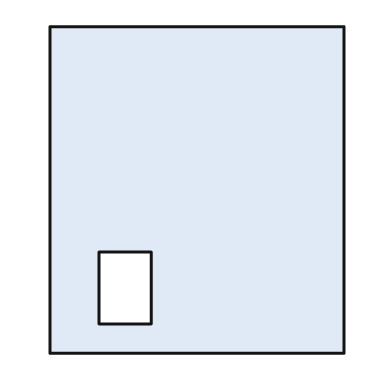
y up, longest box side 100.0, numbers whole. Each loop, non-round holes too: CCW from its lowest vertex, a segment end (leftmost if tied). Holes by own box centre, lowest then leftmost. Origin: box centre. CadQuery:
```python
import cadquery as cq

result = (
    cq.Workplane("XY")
    .moveTo(-45.0, -50.0)
    .lineTo(45.0, -50.0)
    .lineTo(45.0, 50.0)
    .lineTo(-45.0, 50.0)
    .close()
    .moveTo(-30.0, -41.0)
    .lineTo(-14.0, -41.0)
    .lineTo(-14.0, -19.0)
    .lineTo(-30.0, -19.0)
    .close()
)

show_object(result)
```